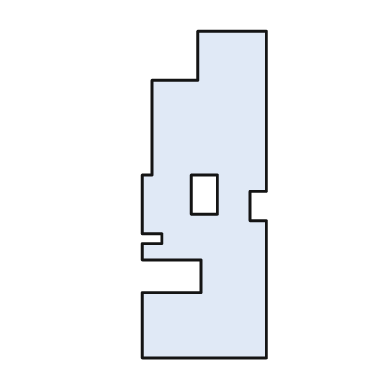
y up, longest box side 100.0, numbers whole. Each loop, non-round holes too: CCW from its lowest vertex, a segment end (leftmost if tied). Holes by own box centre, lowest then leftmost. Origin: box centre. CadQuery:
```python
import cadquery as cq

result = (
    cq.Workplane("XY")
    .moveTo(-19.0, -50.0)
    .lineTo(19.0, -50.0)
    .lineTo(19.0, -8.0)
    .lineTo(14.0, -8.0)
    .lineTo(14.0, 1.0)
    .lineTo(19.0, 1.0)
    .lineTo(19.0, 50.0)
    .lineTo(-2.0, 50.0)
    .lineTo(-2.0, 35.0)
    .lineTo(-16.0, 35.0)
    .lineTo(-16.0, 6.0)
    .lineTo(-19.0, 6.0)
    .lineTo(-19.0, -12.0)
    .lineTo(-13.0, -12.0)
    .lineTo(-13.0, -15.0)
    .lineTo(-19.0, -15.0)
    .lineTo(-19.0, -20.0)
    .lineTo(-1.0, -20.0)
    .lineTo(-1.0, -30.0)
    .lineTo(-19.0, -30.0)
    .close()
    .moveTo(-4.0, -6.0)
    .lineTo(4.0, -6.0)
    .lineTo(4.0, 6.0)
    .lineTo(-4.0, 6.0)
    .close()
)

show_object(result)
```